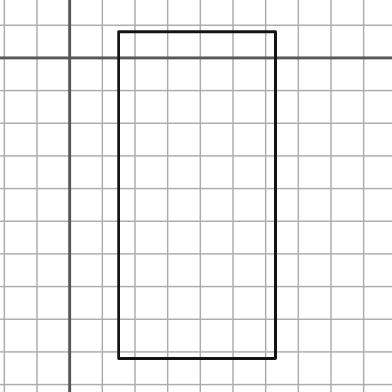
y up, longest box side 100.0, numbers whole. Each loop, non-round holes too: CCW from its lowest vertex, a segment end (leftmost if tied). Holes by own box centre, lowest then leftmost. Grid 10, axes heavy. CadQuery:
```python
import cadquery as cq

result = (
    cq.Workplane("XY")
    .moveTo(15.0, -92.0)
    .lineTo(63.0, -92.0)
    .lineTo(63.0, 8.0)
    .lineTo(15.0, 8.0)
    .close()
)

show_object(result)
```